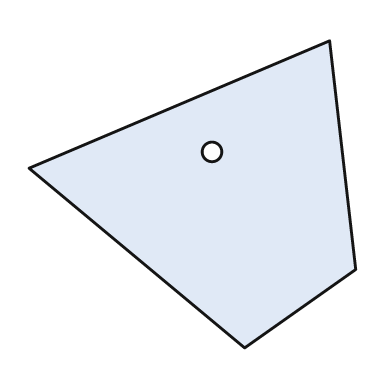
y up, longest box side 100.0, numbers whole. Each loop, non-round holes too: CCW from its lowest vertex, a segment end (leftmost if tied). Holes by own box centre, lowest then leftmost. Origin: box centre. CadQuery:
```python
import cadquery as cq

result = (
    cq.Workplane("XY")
    .moveTo(16.0, -47.0)
    .lineTo(50.0, -23.0)
    .lineTo(42.0, 47.0)
    .lineTo(-50.0, 8.0)
    .close()
    .moveTo(6.0, 13.0)
    .circle(3.0)
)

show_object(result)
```